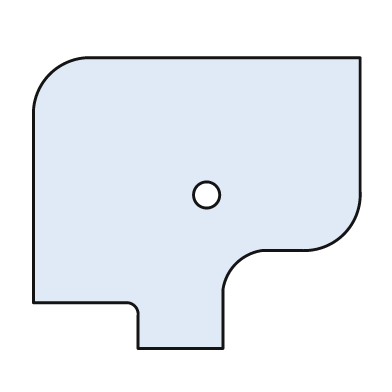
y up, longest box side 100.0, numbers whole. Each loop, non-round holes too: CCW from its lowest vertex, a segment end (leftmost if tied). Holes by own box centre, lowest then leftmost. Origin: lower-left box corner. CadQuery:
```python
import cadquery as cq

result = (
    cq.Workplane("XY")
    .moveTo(32.0, 0.0)
    .lineTo(58.0, 0.0)
    .lineTo(58.0, 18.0)
    .threePointArc((62.0, 26.0), (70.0, 30.0))
    .lineTo(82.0, 30.0)
    .threePointArc((95.0, 35.0), (100.0, 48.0))
    .lineTo(100.0, 89.0)
    .lineTo(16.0, 89.0)
    .threePointArc((5.0, 84.0), (0.0, 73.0))
    .lineTo(0.0, 14.0)
    .lineTo(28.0, 14.0)
    .threePointArc((31.0, 13.0), (32.0, 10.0))
    .close()
    .moveTo(53.0, 47.0)
    .circle(4.0)
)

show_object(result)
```